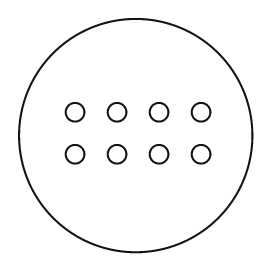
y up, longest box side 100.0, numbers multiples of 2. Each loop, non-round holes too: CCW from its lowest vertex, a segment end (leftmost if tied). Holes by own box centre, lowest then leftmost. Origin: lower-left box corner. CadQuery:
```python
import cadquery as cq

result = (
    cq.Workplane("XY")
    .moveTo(50.0, 50.0)
    .circle(50.0)
    .moveTo(24.0, 42.0)
    .circle(4.0)
    .moveTo(42.0, 42.0)
    .circle(4.0)
    .moveTo(60.0, 42.0)
    .circle(4.0)
    .moveTo(78.0, 42.0)
    .circle(4.0)
    .moveTo(24.0, 60.0)
    .circle(4.0)
    .moveTo(42.0, 60.0)
    .circle(4.0)
    .moveTo(60.0, 60.0)
    .circle(4.0)
    .moveTo(78.0, 60.0)
    .circle(4.0)
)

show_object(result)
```